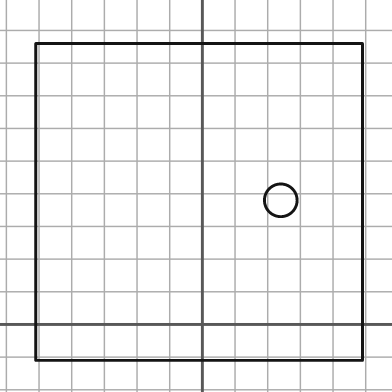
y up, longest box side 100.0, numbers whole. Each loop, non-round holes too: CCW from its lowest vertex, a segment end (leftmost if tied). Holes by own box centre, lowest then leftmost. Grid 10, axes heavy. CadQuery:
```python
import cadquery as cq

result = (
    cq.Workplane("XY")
    .moveTo(-51.0, -11.0)
    .lineTo(49.0, -11.0)
    .lineTo(49.0, 86.0)
    .lineTo(-51.0, 86.0)
    .close()
    .moveTo(24.0, 38.0)
    .circle(5.0)
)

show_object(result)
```